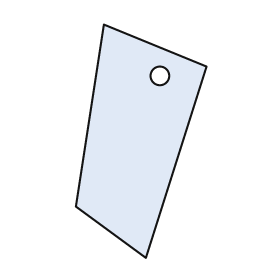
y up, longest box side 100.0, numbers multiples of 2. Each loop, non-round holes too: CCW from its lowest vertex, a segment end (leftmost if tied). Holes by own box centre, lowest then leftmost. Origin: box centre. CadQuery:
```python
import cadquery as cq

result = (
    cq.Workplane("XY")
    .moveTo(2.0, -50.0)
    .lineTo(28.0, 32.0)
    .lineTo(-16.0, 50.0)
    .lineTo(-28.0, -28.0)
    .close()
    .moveTo(8.0, 28.0)
    .circle(4.0)
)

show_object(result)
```